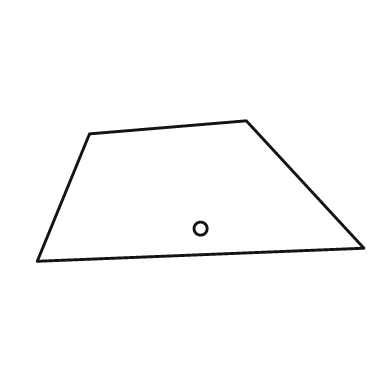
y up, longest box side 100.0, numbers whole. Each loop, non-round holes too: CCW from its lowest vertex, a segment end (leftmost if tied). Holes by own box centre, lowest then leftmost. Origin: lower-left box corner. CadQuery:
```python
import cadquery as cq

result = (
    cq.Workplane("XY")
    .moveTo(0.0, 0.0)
    .lineTo(100.0, 4.0)
    .lineTo(64.0, 43.0)
    .lineTo(16.0, 39.0)
    .close()
    .moveTo(50.0, 10.0)
    .circle(2.0)
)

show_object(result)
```